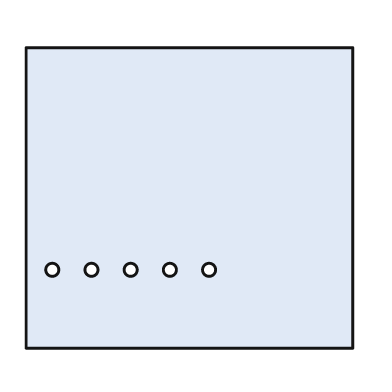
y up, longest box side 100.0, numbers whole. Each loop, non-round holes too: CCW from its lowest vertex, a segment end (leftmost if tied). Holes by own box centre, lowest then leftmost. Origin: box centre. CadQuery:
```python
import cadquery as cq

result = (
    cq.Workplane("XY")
    .moveTo(-50.0, -46.0)
    .lineTo(50.0, -46.0)
    .lineTo(50.0, 46.0)
    .lineTo(-50.0, 46.0)
    .close()
    .moveTo(-42.0, -22.0)
    .circle(2.0)
    .moveTo(-30.0, -22.0)
    .circle(2.0)
    .moveTo(-18.0, -22.0)
    .circle(2.0)
    .moveTo(-6.0, -22.0)
    .circle(2.0)
    .moveTo(6.0, -22.0)
    .circle(2.0)
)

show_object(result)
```